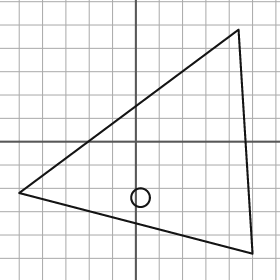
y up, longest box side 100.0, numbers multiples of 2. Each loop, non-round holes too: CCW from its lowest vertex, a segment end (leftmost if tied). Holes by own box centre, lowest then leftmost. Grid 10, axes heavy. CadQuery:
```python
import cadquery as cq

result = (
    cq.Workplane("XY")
    .moveTo(50.0, -48.0)
    .lineTo(44.0, 48.0)
    .lineTo(-50.0, -22.0)
    .close()
    .moveTo(2.0, -24.0)
    .circle(4.0)
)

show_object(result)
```